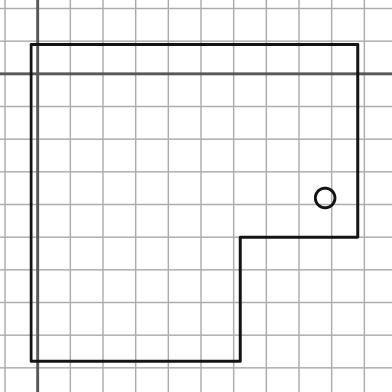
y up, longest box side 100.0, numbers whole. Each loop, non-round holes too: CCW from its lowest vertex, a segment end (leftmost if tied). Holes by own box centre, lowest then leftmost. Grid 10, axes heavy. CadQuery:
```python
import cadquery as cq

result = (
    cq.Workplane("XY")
    .moveTo(-2.0, -88.0)
    .lineTo(62.0, -88.0)
    .lineTo(62.0, -50.0)
    .lineTo(98.0, -50.0)
    .lineTo(98.0, 9.0)
    .lineTo(-2.0, 9.0)
    .close()
    .moveTo(88.0, -38.0)
    .circle(3.0)
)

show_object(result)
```